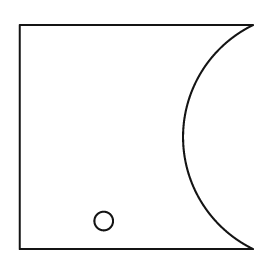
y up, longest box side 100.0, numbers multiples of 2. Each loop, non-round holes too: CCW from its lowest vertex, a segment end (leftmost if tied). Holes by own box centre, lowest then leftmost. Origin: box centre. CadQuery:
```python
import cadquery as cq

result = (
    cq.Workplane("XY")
    .moveTo(-50.0, -48.0)
    .lineTo(50.0, -48.0)
    .threePointArc((20.0, 0.0), (50.0, 48.0))
    .lineTo(-50.0, 48.0)
    .close()
    .moveTo(-14.0, -36.0)
    .circle(4.0)
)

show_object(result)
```